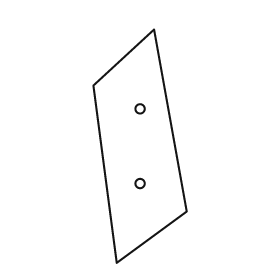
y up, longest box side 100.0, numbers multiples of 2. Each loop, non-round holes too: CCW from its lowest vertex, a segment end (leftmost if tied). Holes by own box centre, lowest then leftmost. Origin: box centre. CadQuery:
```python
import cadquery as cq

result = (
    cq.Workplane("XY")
    .moveTo(-10.0, -50.0)
    .lineTo(20.0, -28.0)
    .lineTo(6.0, 50.0)
    .lineTo(-20.0, 26.0)
    .close()
    .moveTo(0.0, -16.0)
    .circle(2.0)
    .moveTo(0.0, 16.0)
    .circle(2.0)
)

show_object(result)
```